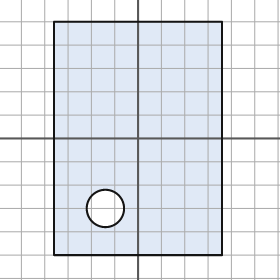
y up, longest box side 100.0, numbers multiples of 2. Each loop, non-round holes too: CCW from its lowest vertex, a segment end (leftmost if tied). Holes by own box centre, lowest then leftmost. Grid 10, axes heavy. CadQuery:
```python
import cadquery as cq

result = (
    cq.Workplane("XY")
    .moveTo(-36.0, -50.0)
    .lineTo(36.0, -50.0)
    .lineTo(36.0, 50.0)
    .lineTo(-36.0, 50.0)
    .close()
    .moveTo(-14.0, -30.0)
    .circle(8.0)
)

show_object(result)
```